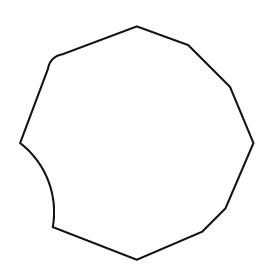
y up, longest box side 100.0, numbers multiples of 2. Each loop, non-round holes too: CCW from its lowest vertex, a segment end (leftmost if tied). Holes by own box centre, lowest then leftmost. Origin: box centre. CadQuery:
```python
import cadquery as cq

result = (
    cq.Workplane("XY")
    .moveTo(0.0, -50.0)
    .lineTo(28.0, -38.0)
    .lineTo(38.0, -28.0)
    .lineTo(50.0, 0.0)
    .lineTo(40.0, 24.0)
    .lineTo(22.0, 42.0)
    .lineTo(0.0, 50.0)
    .lineTo(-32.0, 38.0)
    .threePointArc((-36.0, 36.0), (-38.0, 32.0))
    .lineTo(-50.0, 0.0)
    .threePointArc((-38.0, -16.0), (-36.0, -36.0))
    .close()
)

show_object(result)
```